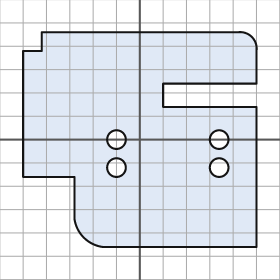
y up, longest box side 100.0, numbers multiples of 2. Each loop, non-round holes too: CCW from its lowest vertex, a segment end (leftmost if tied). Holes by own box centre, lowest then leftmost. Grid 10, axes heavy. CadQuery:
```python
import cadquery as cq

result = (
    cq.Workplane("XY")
    .moveTo(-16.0, -46.0)
    .lineTo(50.0, -46.0)
    .lineTo(50.0, 14.0)
    .lineTo(10.0, 14.0)
    .lineTo(10.0, 24.0)
    .lineTo(50.0, 24.0)
    .lineTo(50.0, 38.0)
    .threePointArc((48.0, 44.0), (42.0, 46.0))
    .lineTo(-42.0, 46.0)
    .lineTo(-42.0, 38.0)
    .lineTo(-50.0, 38.0)
    .lineTo(-50.0, -16.0)
    .lineTo(-28.0, -16.0)
    .lineTo(-28.0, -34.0)
    .threePointArc((-24.0, -42.0), (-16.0, -46.0))
    .close()
    .moveTo(-10.0, -12.0)
    .circle(4.0)
    .moveTo(34.0, -12.0)
    .circle(4.0)
    .moveTo(-10.0, 0.0)
    .circle(4.0)
    .moveTo(34.0, 0.0)
    .circle(4.0)
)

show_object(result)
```